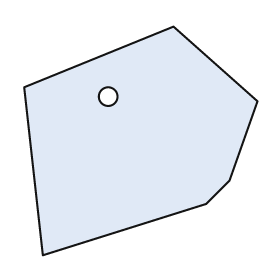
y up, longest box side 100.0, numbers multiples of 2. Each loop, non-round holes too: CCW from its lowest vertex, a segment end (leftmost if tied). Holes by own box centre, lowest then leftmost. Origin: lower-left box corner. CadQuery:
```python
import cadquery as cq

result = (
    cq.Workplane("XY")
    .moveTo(8.0, 0.0)
    .lineTo(78.0, 22.0)
    .lineTo(88.0, 32.0)
    .lineTo(100.0, 66.0)
    .lineTo(64.0, 98.0)
    .lineTo(0.0, 72.0)
    .close()
    .moveTo(36.0, 68.0)
    .circle(4.0)
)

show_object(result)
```